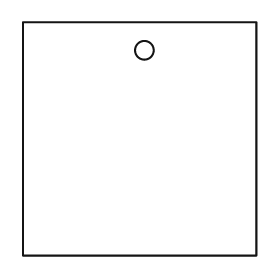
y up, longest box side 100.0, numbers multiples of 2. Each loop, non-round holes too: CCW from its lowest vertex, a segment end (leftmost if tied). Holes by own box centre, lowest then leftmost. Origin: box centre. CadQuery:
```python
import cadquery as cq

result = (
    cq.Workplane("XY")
    .moveTo(-50.0, -50.0)
    .lineTo(50.0, -50.0)
    .lineTo(50.0, 50.0)
    .lineTo(-50.0, 50.0)
    .close()
    .moveTo(2.0, 38.0)
    .circle(4.0)
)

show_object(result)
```